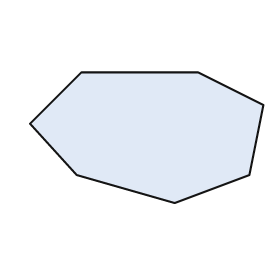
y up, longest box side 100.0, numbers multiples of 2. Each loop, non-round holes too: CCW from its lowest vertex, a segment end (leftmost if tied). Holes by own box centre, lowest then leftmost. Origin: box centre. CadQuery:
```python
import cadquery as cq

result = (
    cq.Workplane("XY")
    .moveTo(12.0, -28.0)
    .lineTo(44.0, -16.0)
    .lineTo(50.0, 14.0)
    .lineTo(22.0, 28.0)
    .lineTo(-28.0, 28.0)
    .lineTo(-50.0, 6.0)
    .lineTo(-30.0, -16.0)
    .close()
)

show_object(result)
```